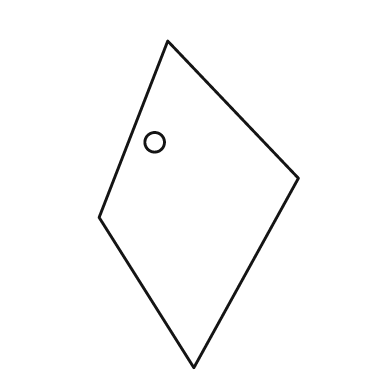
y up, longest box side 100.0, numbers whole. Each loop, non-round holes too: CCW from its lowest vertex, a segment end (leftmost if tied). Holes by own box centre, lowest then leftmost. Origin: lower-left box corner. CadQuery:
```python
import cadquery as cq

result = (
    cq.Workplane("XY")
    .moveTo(29.0, 0.0)
    .lineTo(61.0, 58.0)
    .lineTo(21.0, 100.0)
    .lineTo(0.0, 46.0)
    .close()
    .moveTo(17.0, 69.0)
    .circle(3.0)
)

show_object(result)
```